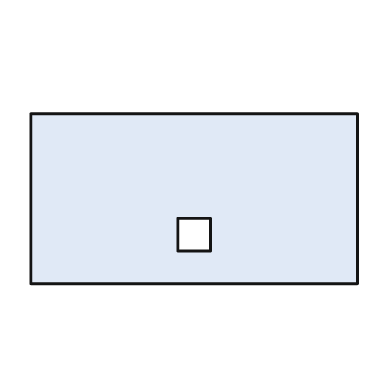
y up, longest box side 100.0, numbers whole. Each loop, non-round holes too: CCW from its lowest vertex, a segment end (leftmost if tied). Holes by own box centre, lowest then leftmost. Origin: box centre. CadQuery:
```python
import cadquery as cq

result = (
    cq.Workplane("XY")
    .moveTo(-50.0, -26.0)
    .lineTo(50.0, -26.0)
    .lineTo(50.0, 26.0)
    .lineTo(-50.0, 26.0)
    .close()
    .moveTo(-5.0, -16.0)
    .lineTo(5.0, -16.0)
    .lineTo(5.0, -6.0)
    .lineTo(-5.0, -6.0)
    .close()
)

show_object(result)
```